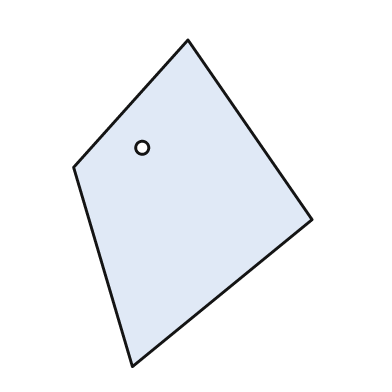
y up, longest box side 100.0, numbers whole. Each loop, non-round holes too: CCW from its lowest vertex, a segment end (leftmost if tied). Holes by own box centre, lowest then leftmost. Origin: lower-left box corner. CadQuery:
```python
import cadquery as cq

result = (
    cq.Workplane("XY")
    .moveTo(18.0, 0.0)
    .lineTo(73.0, 45.0)
    .lineTo(35.0, 100.0)
    .lineTo(0.0, 61.0)
    .close()
    .moveTo(21.0, 67.0)
    .circle(2.0)
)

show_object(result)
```